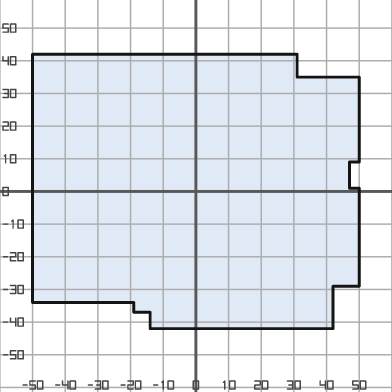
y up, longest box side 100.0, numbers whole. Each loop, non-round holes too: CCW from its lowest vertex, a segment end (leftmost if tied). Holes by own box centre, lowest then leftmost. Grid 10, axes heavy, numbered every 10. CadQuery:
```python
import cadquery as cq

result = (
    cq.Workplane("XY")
    .moveTo(-14.0, -42.0)
    .lineTo(42.0, -42.0)
    .lineTo(42.0, -29.0)
    .lineTo(50.0, -29.0)
    .lineTo(50.0, 1.0)
    .lineTo(47.0, 1.0)
    .lineTo(47.0, 9.0)
    .lineTo(50.0, 9.0)
    .lineTo(50.0, 35.0)
    .lineTo(31.0, 35.0)
    .lineTo(31.0, 42.0)
    .lineTo(-50.0, 42.0)
    .lineTo(-50.0, -34.0)
    .lineTo(-19.0, -34.0)
    .lineTo(-19.0, -37.0)
    .lineTo(-14.0, -37.0)
    .close()
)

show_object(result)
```